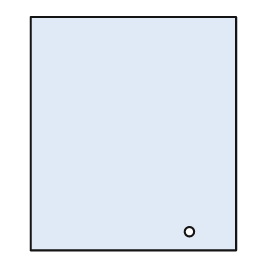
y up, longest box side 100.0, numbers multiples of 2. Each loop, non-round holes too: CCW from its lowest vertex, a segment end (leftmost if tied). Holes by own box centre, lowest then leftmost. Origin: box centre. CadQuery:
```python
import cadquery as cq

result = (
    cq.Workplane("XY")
    .moveTo(-44.0, -50.0)
    .lineTo(44.0, -50.0)
    .lineTo(44.0, 50.0)
    .lineTo(-44.0, 50.0)
    .close()
    .moveTo(24.0, -42.0)
    .circle(2.0)
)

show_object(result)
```